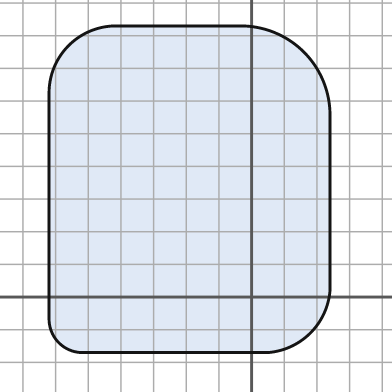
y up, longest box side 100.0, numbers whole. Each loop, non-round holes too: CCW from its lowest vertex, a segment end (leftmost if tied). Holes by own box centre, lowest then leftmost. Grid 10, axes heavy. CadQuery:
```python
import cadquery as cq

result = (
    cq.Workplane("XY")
    .moveTo(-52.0, -17.0)
    .lineTo(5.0, -17.0)
    .threePointArc((18.0, -11.0), (24.0, 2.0))
    .lineTo(24.0, 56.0)
    .threePointArc((16.0, 75.0), (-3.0, 83.0))
    .lineTo(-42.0, 83.0)
    .threePointArc((-56.0, 77.0), (-62.0, 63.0))
    .lineTo(-62.0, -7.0)
    .threePointArc((-59.0, -14.0), (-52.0, -17.0))
    .close()
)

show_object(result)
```